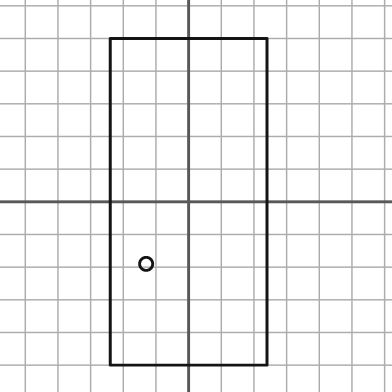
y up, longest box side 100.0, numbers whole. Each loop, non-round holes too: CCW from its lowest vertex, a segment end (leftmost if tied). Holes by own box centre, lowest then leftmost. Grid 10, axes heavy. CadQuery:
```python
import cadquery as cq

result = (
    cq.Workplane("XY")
    .moveTo(-24.0, -50.0)
    .lineTo(24.0, -50.0)
    .lineTo(24.0, 50.0)
    .lineTo(-24.0, 50.0)
    .close()
    .moveTo(-13.0, -19.0)
    .circle(2.0)
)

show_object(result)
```